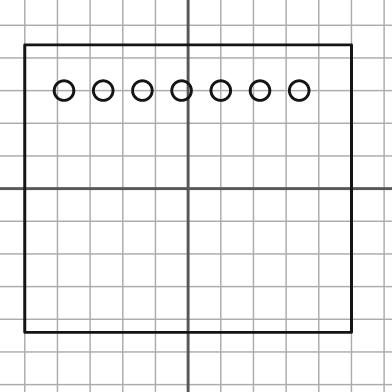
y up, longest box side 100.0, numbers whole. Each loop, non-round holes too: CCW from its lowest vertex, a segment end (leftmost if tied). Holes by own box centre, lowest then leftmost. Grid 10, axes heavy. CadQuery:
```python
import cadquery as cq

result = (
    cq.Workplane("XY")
    .moveTo(-50.0, -44.0)
    .lineTo(50.0, -44.0)
    .lineTo(50.0, 44.0)
    .lineTo(-50.0, 44.0)
    .close()
    .moveTo(-38.0, 30.0)
    .circle(3.0)
    .moveTo(-26.0, 30.0)
    .circle(3.0)
    .moveTo(-14.0, 30.0)
    .circle(3.0)
    .moveTo(-2.0, 30.0)
    .circle(3.0)
    .moveTo(10.0, 30.0)
    .circle(3.0)
    .moveTo(22.0, 30.0)
    .circle(3.0)
    .moveTo(34.0, 30.0)
    .circle(3.0)
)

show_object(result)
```